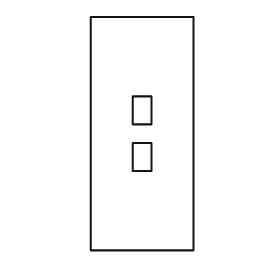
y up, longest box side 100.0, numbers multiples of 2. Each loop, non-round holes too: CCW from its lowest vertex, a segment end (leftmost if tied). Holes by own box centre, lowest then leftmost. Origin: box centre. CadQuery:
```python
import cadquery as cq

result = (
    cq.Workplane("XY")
    .moveTo(-22.0, -50.0)
    .lineTo(22.0, -50.0)
    .lineTo(22.0, 50.0)
    .lineTo(-22.0, 50.0)
    .close()
    .moveTo(-4.0, -16.0)
    .lineTo(4.0, -16.0)
    .lineTo(4.0, -4.0)
    .lineTo(-4.0, -4.0)
    .close()
    .moveTo(-4.0, 4.0)
    .lineTo(4.0, 4.0)
    .lineTo(4.0, 16.0)
    .lineTo(-4.0, 16.0)
    .close()
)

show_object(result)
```